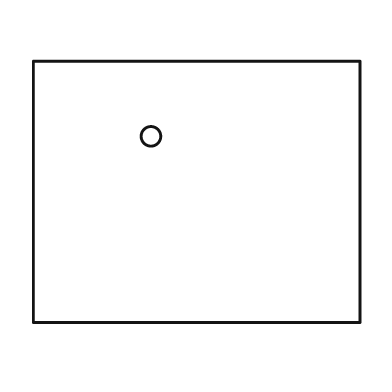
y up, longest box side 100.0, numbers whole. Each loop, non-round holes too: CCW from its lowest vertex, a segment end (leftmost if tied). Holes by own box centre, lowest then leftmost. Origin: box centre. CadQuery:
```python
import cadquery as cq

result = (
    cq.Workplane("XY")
    .moveTo(-50.0, -40.0)
    .lineTo(50.0, -40.0)
    .lineTo(50.0, 40.0)
    .lineTo(-50.0, 40.0)
    .close()
    .moveTo(-14.0, 17.0)
    .circle(3.0)
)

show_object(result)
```